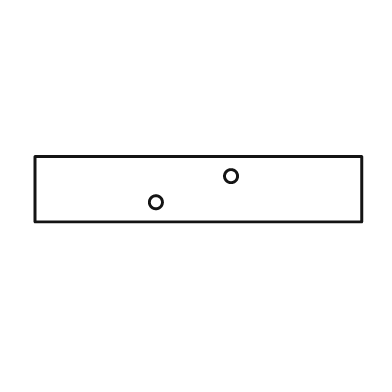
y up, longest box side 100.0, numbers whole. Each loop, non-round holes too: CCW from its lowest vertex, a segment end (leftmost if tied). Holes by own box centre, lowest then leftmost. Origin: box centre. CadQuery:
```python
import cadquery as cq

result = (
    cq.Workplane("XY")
    .moveTo(-50.0, -10.0)
    .lineTo(50.0, -10.0)
    .lineTo(50.0, 10.0)
    .lineTo(-50.0, 10.0)
    .close()
    .moveTo(-13.0, -4.0)
    .circle(2.0)
    .moveTo(10.0, 4.0)
    .circle(2.0)
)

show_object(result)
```